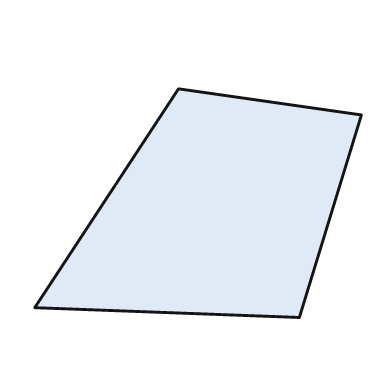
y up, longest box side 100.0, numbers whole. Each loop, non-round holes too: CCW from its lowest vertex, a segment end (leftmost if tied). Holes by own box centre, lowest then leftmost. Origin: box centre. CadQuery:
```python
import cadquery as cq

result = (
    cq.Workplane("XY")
    .moveTo(31.0, -35.0)
    .lineTo(50.0, 27.0)
    .lineTo(-6.0, 35.0)
    .lineTo(-50.0, -32.0)
    .close()
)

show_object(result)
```